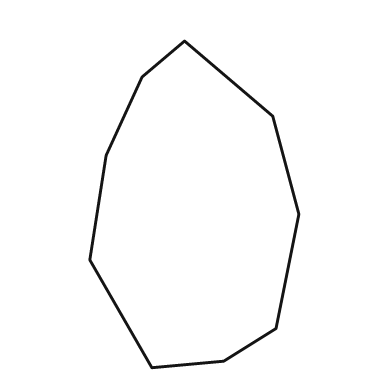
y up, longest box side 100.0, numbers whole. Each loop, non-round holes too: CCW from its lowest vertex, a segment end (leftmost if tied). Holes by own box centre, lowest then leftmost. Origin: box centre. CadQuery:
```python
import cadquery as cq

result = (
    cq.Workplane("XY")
    .moveTo(-13.0, -50.0)
    .lineTo(9.0, -48.0)
    .lineTo(25.0, -38.0)
    .lineTo(32.0, -3.0)
    .lineTo(24.0, 27.0)
    .lineTo(-3.0, 50.0)
    .lineTo(-16.0, 39.0)
    .lineTo(-27.0, 15.0)
    .lineTo(-32.0, -17.0)
    .close()
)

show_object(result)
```